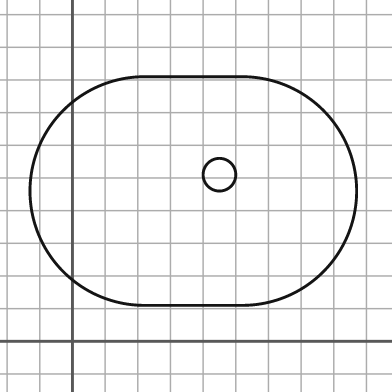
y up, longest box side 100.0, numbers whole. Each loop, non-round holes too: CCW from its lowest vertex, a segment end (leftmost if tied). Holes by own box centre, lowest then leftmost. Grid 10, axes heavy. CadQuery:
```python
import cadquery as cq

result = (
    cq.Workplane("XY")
    .moveTo(22.0, 11.0)
    .lineTo(52.0, 11.0)
    .threePointArc((87.0, 46.0), (52.0, 81.0))
    .lineTo(22.0, 81.0)
    .threePointArc((-13.0, 46.0), (22.0, 11.0))
    .close()
    .moveTo(45.0, 51.0)
    .circle(5.0)
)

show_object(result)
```